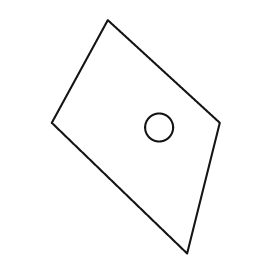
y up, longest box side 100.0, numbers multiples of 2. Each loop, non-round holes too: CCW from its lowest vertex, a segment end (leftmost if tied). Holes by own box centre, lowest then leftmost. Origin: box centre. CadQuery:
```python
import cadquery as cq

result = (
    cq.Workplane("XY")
    .moveTo(22.0, -50.0)
    .lineTo(36.0, 6.0)
    .lineTo(-12.0, 50.0)
    .lineTo(-36.0, 6.0)
    .close()
    .moveTo(10.0, 4.0)
    .circle(6.0)
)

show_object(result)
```